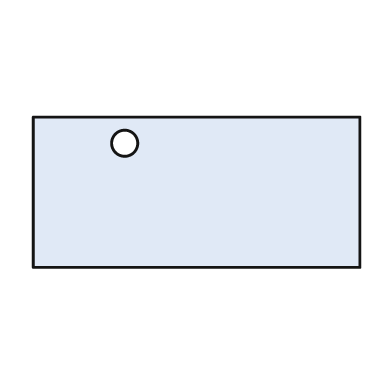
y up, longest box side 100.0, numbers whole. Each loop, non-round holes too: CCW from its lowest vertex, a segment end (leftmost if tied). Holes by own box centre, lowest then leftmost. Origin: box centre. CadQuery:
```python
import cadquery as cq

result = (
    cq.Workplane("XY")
    .moveTo(-50.0, -23.0)
    .lineTo(50.0, -23.0)
    .lineTo(50.0, 23.0)
    .lineTo(-50.0, 23.0)
    .close()
    .moveTo(-22.0, 15.0)
    .circle(4.0)
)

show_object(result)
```